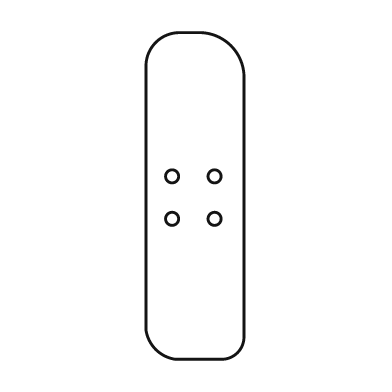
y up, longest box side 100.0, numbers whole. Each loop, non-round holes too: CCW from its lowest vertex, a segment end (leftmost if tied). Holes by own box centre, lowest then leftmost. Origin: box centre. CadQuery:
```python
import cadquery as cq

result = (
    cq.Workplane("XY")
    .moveTo(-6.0, -50.0)
    .lineTo(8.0, -50.0)
    .threePointArc((13.0, -48.0), (15.0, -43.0))
    .lineTo(15.0, 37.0)
    .threePointArc((11.0, 46.0), (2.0, 50.0))
    .lineTo(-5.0, 50.0)
    .threePointArc((-12.0, 47.0), (-15.0, 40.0))
    .lineTo(-15.0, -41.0)
    .threePointArc((-12.0, -47.0), (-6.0, -50.0))
    .close()
    .moveTo(-7.0, -7.0)
    .circle(2.0)
    .moveTo(6.0, -7.0)
    .circle(2.0)
    .moveTo(-7.0, 6.0)
    .circle(2.0)
    .moveTo(6.0, 6.0)
    .circle(2.0)
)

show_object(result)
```